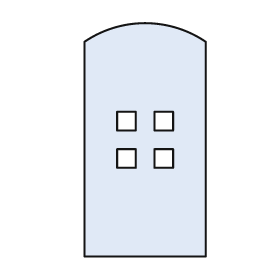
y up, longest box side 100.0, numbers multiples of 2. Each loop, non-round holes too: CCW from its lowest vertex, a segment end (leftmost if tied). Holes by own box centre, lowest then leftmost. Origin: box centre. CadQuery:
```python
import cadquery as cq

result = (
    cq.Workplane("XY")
    .moveTo(-26.0, -50.0)
    .lineTo(26.0, -50.0)
    .lineTo(26.0, 42.0)
    .threePointArc((0.0, 50.0), (-26.0, 42.0))
    .close()
    .moveTo(-12.0, -12.0)
    .lineTo(-4.0, -12.0)
    .lineTo(-4.0, -4.0)
    .lineTo(-12.0, -4.0)
    .close()
    .moveTo(4.0, -12.0)
    .lineTo(12.0, -12.0)
    .lineTo(12.0, -4.0)
    .lineTo(4.0, -4.0)
    .close()
    .moveTo(-12.0, 4.0)
    .lineTo(-4.0, 4.0)
    .lineTo(-4.0, 12.0)
    .lineTo(-12.0, 12.0)
    .close()
    .moveTo(4.0, 4.0)
    .lineTo(12.0, 4.0)
    .lineTo(12.0, 12.0)
    .lineTo(4.0, 12.0)
    .close()
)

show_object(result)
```